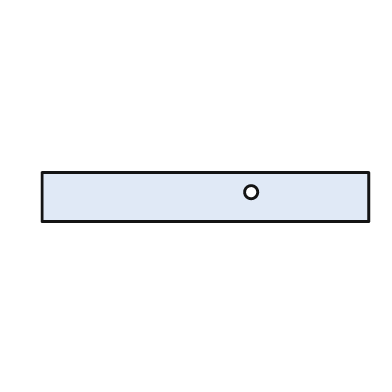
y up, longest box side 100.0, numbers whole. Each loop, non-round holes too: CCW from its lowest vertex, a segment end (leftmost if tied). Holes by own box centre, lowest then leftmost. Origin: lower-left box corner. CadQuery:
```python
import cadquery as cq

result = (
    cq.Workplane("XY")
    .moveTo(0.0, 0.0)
    .lineTo(100.0, 0.0)
    .lineTo(100.0, 15.0)
    .lineTo(0.0, 15.0)
    .close()
    .moveTo(64.0, 9.0)
    .circle(2.0)
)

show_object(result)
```